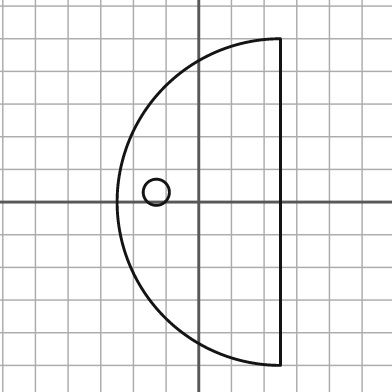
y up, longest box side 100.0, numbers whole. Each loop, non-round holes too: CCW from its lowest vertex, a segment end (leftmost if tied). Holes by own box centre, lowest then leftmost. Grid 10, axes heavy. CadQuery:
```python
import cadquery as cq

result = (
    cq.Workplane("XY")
    .moveTo(25.0, -50.0)
    .lineTo(25.0, 50.0)
    .threePointArc((-25.0, 0.0), (25.0, -50.0))
    .close()
    .moveTo(-13.0, 3.0)
    .circle(4.0)
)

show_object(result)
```